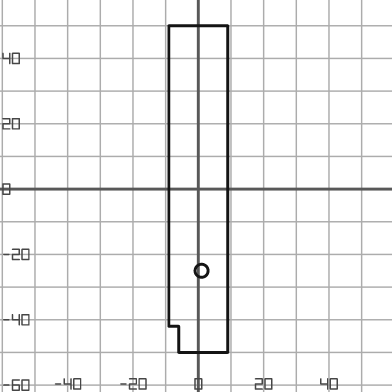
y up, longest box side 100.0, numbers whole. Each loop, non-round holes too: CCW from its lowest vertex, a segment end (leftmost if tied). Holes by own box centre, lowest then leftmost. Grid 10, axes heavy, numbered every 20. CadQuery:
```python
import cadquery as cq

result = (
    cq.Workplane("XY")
    .moveTo(-6.0, -50.0)
    .lineTo(9.0, -50.0)
    .lineTo(9.0, 50.0)
    .lineTo(-9.0, 50.0)
    .lineTo(-9.0, -42.0)
    .lineTo(-6.0, -42.0)
    .close()
    .moveTo(1.0, -25.0)
    .circle(2.0)
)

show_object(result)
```